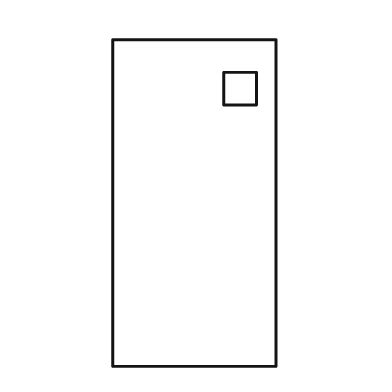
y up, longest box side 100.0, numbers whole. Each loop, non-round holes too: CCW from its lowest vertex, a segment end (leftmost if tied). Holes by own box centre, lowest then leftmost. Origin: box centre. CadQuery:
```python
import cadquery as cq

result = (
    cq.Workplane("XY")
    .moveTo(-25.0, -50.0)
    .lineTo(25.0, -50.0)
    .lineTo(25.0, 50.0)
    .lineTo(-25.0, 50.0)
    .close()
    .moveTo(9.0, 30.0)
    .lineTo(19.0, 30.0)
    .lineTo(19.0, 40.0)
    .lineTo(9.0, 40.0)
    .close()
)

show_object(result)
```